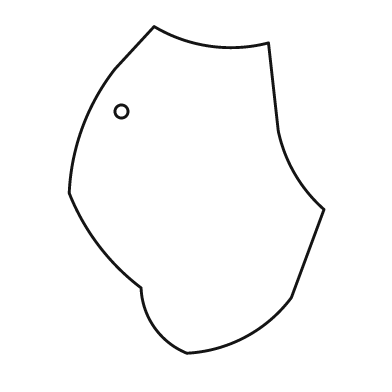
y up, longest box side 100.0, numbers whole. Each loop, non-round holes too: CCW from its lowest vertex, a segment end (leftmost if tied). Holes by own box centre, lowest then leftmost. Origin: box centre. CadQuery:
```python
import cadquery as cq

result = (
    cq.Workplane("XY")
    .moveTo(-3.0, -50.0)
    .threePointArc((15.0, -45.0), (29.0, -33.0))
    .lineTo(39.0, -6.0)
    .threePointArc((30.0, 5.0), (25.0, 18.0))
    .lineTo(22.0, 45.0)
    .threePointArc((4.0, 44.0), (-13.0, 50.0))
    .lineTo(-25.0, 37.0)
    .threePointArc((-35.0, 19.0), (-39.0, -1.0))
    .threePointArc((-30.0, -17.0), (-17.0, -30.0))
    .threePointArc((-13.0, -42.0), (-3.0, -50.0))
    .close()
    .moveTo(-23.0, 24.0)
    .circle(2.0)
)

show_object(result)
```